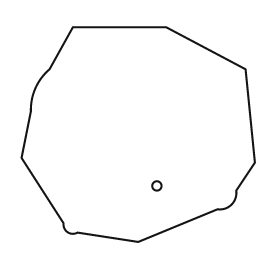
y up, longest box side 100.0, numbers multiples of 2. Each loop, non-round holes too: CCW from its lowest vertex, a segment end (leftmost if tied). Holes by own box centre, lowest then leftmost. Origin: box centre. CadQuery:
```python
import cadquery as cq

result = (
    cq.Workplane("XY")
    .moveTo(0.0, -46.0)
    .lineTo(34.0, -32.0)
    .threePointArc((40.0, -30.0), (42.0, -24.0))
    .lineTo(50.0, -12.0)
    .lineTo(46.0, 28.0)
    .lineTo(12.0, 46.0)
    .lineTo(-28.0, 46.0)
    .lineTo(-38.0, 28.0)
    .threePointArc((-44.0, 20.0), (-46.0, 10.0))
    .lineTo(-50.0, -10.0)
    .lineTo(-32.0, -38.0)
    .threePointArc((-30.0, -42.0), (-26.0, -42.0))
    .close()
    .moveTo(8.0, -22.0)
    .circle(2.0)
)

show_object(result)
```